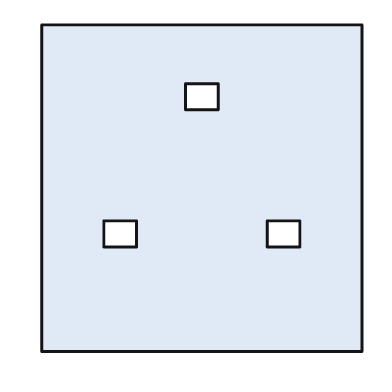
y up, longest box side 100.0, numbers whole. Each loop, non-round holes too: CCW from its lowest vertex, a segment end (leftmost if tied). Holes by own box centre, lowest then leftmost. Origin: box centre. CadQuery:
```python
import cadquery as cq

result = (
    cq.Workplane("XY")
    .moveTo(-49.0, -50.0)
    .lineTo(49.0, -50.0)
    .lineTo(49.0, 50.0)
    .lineTo(-49.0, 50.0)
    .close()
    .moveTo(-30.0, -18.0)
    .lineTo(-20.0, -18.0)
    .lineTo(-20.0, -10.0)
    .lineTo(-30.0, -10.0)
    .close()
    .moveTo(20.0, -18.0)
    .lineTo(30.0, -18.0)
    .lineTo(30.0, -10.0)
    .lineTo(20.0, -10.0)
    .close()
    .moveTo(-5.0, 24.0)
    .lineTo(5.0, 24.0)
    .lineTo(5.0, 32.0)
    .lineTo(-5.0, 32.0)
    .close()
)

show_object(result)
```